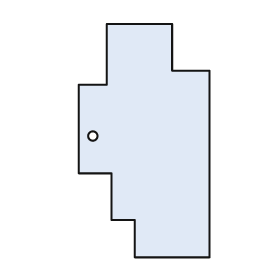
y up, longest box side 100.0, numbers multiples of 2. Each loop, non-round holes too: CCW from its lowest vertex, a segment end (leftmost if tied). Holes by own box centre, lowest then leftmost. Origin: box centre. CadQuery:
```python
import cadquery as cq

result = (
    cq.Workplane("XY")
    .moveTo(-4.0, -50.0)
    .lineTo(28.0, -50.0)
    .lineTo(28.0, 30.0)
    .lineTo(12.0, 30.0)
    .lineTo(12.0, 50.0)
    .lineTo(-16.0, 50.0)
    .lineTo(-16.0, 24.0)
    .lineTo(-28.0, 24.0)
    .lineTo(-28.0, -14.0)
    .lineTo(-14.0, -14.0)
    .lineTo(-14.0, -34.0)
    .lineTo(-4.0, -34.0)
    .close()
    .moveTo(-22.0, 2.0)
    .circle(2.0)
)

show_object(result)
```